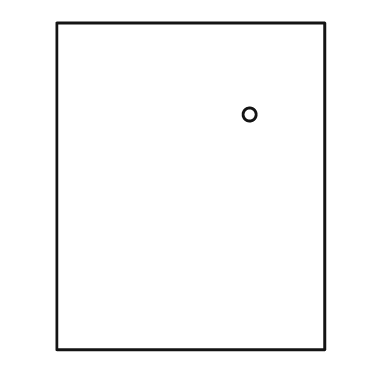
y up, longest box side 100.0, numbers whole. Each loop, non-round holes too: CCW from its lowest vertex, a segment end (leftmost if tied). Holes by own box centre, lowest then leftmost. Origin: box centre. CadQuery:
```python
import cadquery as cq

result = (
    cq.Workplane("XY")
    .moveTo(-41.0, -50.0)
    .lineTo(41.0, -50.0)
    .lineTo(41.0, 50.0)
    .lineTo(-41.0, 50.0)
    .close()
    .moveTo(18.0, 22.0)
    .circle(2.0)
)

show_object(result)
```